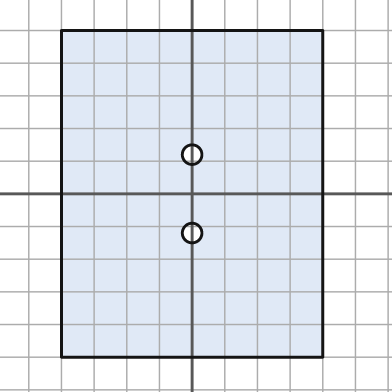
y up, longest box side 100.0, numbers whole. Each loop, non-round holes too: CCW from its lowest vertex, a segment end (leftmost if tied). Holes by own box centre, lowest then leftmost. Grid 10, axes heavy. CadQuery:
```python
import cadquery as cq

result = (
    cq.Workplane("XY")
    .moveTo(-40.0, -50.0)
    .lineTo(40.0, -50.0)
    .lineTo(40.0, 50.0)
    .lineTo(-40.0, 50.0)
    .close()
    .moveTo(0.0, -12.0)
    .circle(3.0)
    .moveTo(0.0, 12.0)
    .circle(3.0)
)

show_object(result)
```